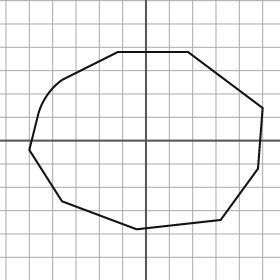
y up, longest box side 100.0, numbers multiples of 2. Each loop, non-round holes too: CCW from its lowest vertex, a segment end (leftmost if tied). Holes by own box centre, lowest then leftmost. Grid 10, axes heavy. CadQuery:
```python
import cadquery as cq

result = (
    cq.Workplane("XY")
    .moveTo(-4.0, -38.0)
    .lineTo(32.0, -34.0)
    .lineTo(48.0, -12.0)
    .lineTo(50.0, 14.0)
    .lineTo(18.0, 38.0)
    .lineTo(-12.0, 38.0)
    .lineTo(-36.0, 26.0)
    .threePointArc((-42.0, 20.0), (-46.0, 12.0))
    .lineTo(-50.0, -4.0)
    .lineTo(-36.0, -26.0)
    .close()
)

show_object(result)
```